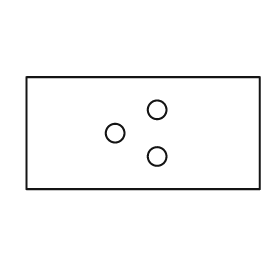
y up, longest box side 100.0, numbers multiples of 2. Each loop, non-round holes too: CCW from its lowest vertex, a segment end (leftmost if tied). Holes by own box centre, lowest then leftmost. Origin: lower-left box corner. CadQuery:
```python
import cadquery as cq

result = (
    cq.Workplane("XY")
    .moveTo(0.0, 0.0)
    .lineTo(100.0, 0.0)
    .lineTo(100.0, 48.0)
    .lineTo(0.0, 48.0)
    .close()
    .moveTo(56.0, 14.0)
    .circle(4.0)
    .moveTo(38.0, 24.0)
    .circle(4.0)
    .moveTo(56.0, 34.0)
    .circle(4.0)
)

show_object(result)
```